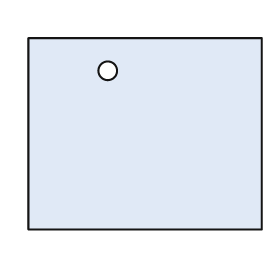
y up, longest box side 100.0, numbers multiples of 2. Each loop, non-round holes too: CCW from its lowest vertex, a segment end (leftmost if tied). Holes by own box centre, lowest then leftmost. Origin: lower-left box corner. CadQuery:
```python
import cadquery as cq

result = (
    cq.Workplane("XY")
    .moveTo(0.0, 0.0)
    .lineTo(100.0, 0.0)
    .lineTo(100.0, 82.0)
    .lineTo(0.0, 82.0)
    .close()
    .moveTo(34.0, 68.0)
    .circle(4.0)
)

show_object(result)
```